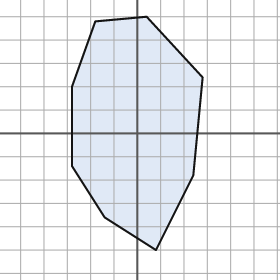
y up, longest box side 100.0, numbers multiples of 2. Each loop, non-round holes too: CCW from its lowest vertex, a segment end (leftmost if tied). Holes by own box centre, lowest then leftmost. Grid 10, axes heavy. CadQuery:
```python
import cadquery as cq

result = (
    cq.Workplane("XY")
    .moveTo(8.0, -50.0)
    .lineTo(24.0, -18.0)
    .lineTo(28.0, 24.0)
    .lineTo(4.0, 50.0)
    .lineTo(-18.0, 48.0)
    .lineTo(-28.0, 20.0)
    .lineTo(-28.0, -14.0)
    .lineTo(-14.0, -36.0)
    .close()
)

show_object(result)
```